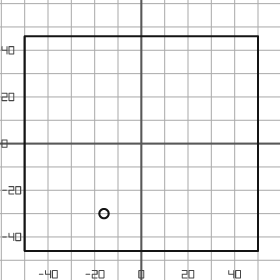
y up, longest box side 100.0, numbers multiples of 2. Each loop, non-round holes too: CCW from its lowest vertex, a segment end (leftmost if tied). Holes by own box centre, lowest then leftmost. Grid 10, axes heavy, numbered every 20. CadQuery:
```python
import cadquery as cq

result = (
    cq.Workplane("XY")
    .moveTo(-50.0, -46.0)
    .lineTo(50.0, -46.0)
    .lineTo(50.0, 46.0)
    .lineTo(-50.0, 46.0)
    .close()
    .moveTo(-16.0, -30.0)
    .circle(2.0)
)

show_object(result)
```